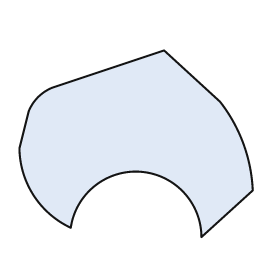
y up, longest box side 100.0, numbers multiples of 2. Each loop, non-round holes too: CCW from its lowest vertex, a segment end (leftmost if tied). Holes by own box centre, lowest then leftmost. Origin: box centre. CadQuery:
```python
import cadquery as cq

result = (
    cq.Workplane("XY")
    .moveTo(28.0, -40.0)
    .lineTo(50.0, -20.0)
    .threePointArc((46.0, 0.0), (36.0, 18.0))
    .lineTo(12.0, 40.0)
    .lineTo(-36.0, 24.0)
    .threePointArc((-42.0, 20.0), (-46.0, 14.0))
    .lineTo(-50.0, -2.0)
    .threePointArc((-44.0, -22.0), (-28.0, -36.0))
    .threePointArc((2.0, -12.0), (28.0, -40.0))
    .close()
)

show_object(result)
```